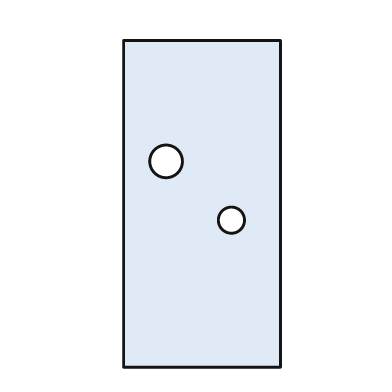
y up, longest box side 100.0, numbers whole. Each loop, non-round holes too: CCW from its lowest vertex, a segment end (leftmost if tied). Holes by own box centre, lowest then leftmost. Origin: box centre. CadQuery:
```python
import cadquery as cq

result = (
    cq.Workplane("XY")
    .moveTo(-24.0, -50.0)
    .lineTo(24.0, -50.0)
    .lineTo(24.0, 50.0)
    .lineTo(-24.0, 50.0)
    .close()
    .moveTo(9.0, -5.0)
    .circle(4.0)
    .moveTo(-11.0, 13.0)
    .circle(5.0)
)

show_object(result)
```